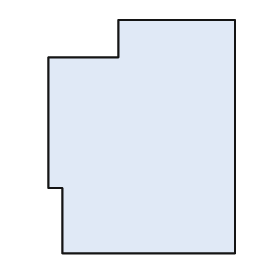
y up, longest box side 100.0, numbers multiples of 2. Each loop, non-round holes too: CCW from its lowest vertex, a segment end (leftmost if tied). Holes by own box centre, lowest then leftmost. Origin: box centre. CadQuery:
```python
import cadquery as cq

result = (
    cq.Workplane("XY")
    .moveTo(-34.0, -50.0)
    .lineTo(40.0, -50.0)
    .lineTo(40.0, 50.0)
    .lineTo(-10.0, 50.0)
    .lineTo(-10.0, 34.0)
    .lineTo(-40.0, 34.0)
    .lineTo(-40.0, -22.0)
    .lineTo(-34.0, -22.0)
    .close()
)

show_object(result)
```